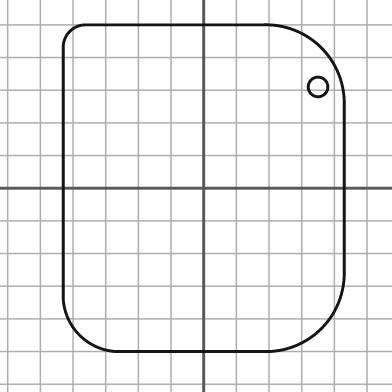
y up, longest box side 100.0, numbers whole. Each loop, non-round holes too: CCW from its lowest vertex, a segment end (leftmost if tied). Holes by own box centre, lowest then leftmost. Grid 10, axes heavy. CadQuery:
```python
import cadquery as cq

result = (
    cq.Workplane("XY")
    .moveTo(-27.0, -50.0)
    .lineTo(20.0, -50.0)
    .threePointArc((36.0, -43.0), (43.0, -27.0))
    .lineTo(43.0, 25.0)
    .threePointArc((36.0, 43.0), (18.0, 50.0))
    .lineTo(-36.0, 50.0)
    .threePointArc((-41.0, 48.0), (-43.0, 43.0))
    .lineTo(-43.0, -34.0)
    .threePointArc((-38.0, -45.0), (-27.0, -50.0))
    .close()
    .moveTo(35.0, 31.0)
    .circle(3.0)
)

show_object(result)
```